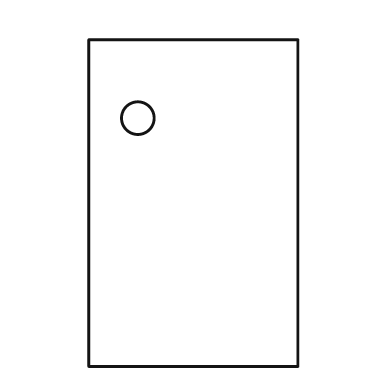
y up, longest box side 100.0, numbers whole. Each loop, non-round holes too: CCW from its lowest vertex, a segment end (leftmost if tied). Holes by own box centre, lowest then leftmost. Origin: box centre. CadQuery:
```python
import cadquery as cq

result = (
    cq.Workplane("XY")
    .moveTo(-32.0, -50.0)
    .lineTo(32.0, -50.0)
    .lineTo(32.0, 50.0)
    .lineTo(-32.0, 50.0)
    .close()
    .moveTo(-17.0, 26.0)
    .circle(5.0)
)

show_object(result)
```